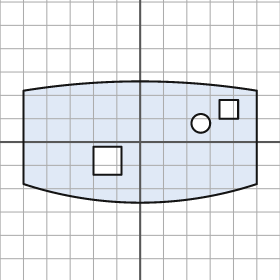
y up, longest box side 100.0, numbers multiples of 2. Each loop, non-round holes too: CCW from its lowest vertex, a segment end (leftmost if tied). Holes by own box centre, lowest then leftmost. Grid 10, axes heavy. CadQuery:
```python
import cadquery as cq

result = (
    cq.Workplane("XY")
    .moveTo(-50.0, -18.0)
    .threePointArc((0.0, -26.0), (50.0, -18.0))
    .lineTo(50.0, 22.0)
    .threePointArc((0.0, 26.0), (-50.0, 22.0))
    .close()
    .moveTo(-20.0, -14.0)
    .lineTo(-8.0, -14.0)
    .lineTo(-8.0, -2.0)
    .lineTo(-20.0, -2.0)
    .close()
    .moveTo(26.0, 8.0)
    .circle(4.0)
    .moveTo(34.0, 10.0)
    .lineTo(42.0, 10.0)
    .lineTo(42.0, 18.0)
    .lineTo(34.0, 18.0)
    .close()
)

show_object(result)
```